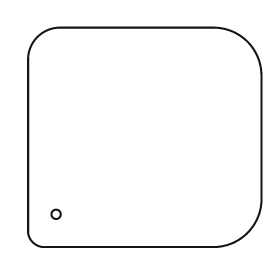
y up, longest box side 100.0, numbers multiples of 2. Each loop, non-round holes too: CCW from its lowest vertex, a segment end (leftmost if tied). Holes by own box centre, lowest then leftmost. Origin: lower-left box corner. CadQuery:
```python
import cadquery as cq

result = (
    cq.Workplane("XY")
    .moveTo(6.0, 0.0)
    .lineTo(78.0, 0.0)
    .threePointArc((94.0, 6.0), (100.0, 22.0))
    .lineTo(100.0, 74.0)
    .threePointArc((94.0, 88.0), (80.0, 94.0))
    .lineTo(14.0, 94.0)
    .threePointArc((4.0, 90.0), (0.0, 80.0))
    .lineTo(0.0, 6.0)
    .threePointArc((2.0, 2.0), (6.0, 0.0))
    .close()
    .moveTo(12.0, 14.0)
    .circle(2.0)
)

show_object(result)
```